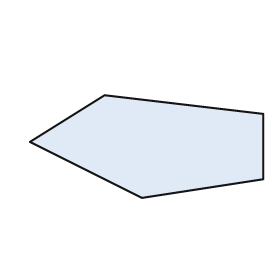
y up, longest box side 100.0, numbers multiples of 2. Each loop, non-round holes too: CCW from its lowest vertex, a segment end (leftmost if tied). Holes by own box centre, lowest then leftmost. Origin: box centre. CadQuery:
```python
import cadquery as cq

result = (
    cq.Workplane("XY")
    .moveTo(-2.0, -22.0)
    .lineTo(50.0, -14.0)
    .lineTo(50.0, 14.0)
    .lineTo(-18.0, 22.0)
    .lineTo(-50.0, 2.0)
    .close()
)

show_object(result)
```